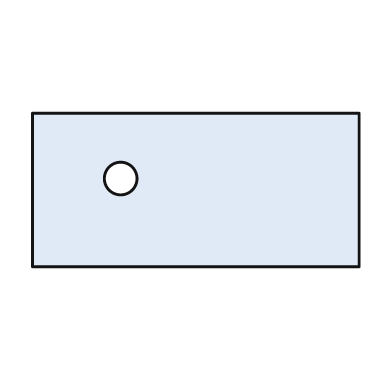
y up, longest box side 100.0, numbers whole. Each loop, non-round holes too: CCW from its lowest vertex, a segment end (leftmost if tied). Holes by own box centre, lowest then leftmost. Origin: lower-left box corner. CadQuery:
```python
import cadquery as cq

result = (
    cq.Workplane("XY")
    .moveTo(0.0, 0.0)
    .lineTo(100.0, 0.0)
    .lineTo(100.0, 47.0)
    .lineTo(0.0, 47.0)
    .close()
    .moveTo(27.0, 27.0)
    .circle(5.0)
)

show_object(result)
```